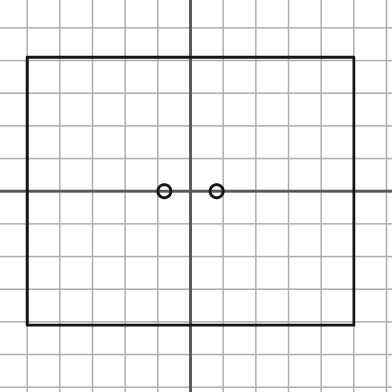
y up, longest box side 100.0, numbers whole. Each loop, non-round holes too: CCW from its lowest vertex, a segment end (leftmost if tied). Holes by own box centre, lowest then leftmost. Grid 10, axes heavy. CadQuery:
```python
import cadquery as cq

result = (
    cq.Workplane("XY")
    .moveTo(-50.0, -41.0)
    .lineTo(50.0, -41.0)
    .lineTo(50.0, 41.0)
    .lineTo(-50.0, 41.0)
    .close()
    .moveTo(-8.0, 0.0)
    .circle(2.0)
    .moveTo(8.0, 0.0)
    .circle(2.0)
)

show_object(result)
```